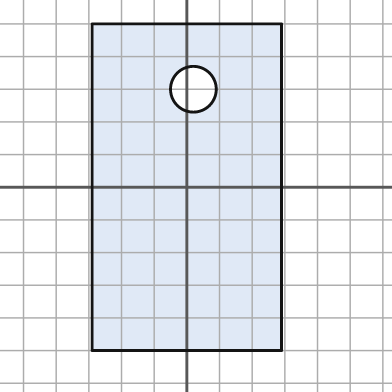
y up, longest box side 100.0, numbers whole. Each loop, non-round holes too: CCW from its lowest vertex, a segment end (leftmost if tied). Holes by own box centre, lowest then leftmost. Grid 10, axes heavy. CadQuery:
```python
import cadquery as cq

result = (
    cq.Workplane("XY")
    .moveTo(-29.0, -50.0)
    .lineTo(29.0, -50.0)
    .lineTo(29.0, 50.0)
    .lineTo(-29.0, 50.0)
    .close()
    .moveTo(2.0, 30.0)
    .circle(7.0)
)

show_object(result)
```